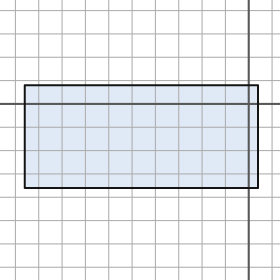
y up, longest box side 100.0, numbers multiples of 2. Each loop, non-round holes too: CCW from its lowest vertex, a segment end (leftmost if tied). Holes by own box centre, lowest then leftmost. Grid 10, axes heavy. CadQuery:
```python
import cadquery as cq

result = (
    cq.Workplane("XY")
    .moveTo(-96.0, -36.0)
    .lineTo(4.0, -36.0)
    .lineTo(4.0, 8.0)
    .lineTo(-96.0, 8.0)
    .close()
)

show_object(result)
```